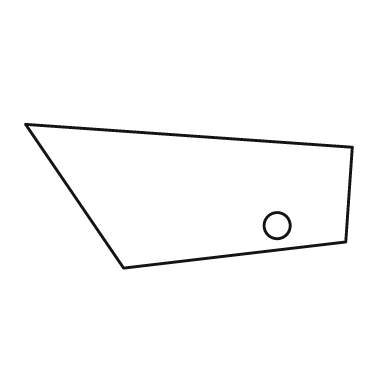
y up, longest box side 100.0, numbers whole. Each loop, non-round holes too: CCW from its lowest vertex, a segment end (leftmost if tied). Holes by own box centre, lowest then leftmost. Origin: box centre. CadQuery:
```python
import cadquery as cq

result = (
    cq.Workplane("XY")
    .moveTo(-20.0, -22.0)
    .lineTo(48.0, -14.0)
    .lineTo(50.0, 15.0)
    .lineTo(-50.0, 22.0)
    .close()
    .moveTo(27.0, -9.0)
    .circle(4.0)
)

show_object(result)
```